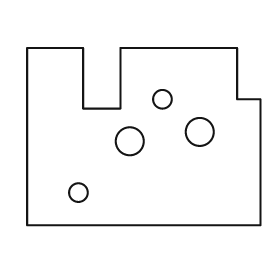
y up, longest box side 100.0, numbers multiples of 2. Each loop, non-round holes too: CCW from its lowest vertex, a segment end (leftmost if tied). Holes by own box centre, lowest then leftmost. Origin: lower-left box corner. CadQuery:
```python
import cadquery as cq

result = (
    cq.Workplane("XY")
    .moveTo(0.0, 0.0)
    .lineTo(100.0, 0.0)
    .lineTo(100.0, 54.0)
    .lineTo(90.0, 54.0)
    .lineTo(90.0, 76.0)
    .lineTo(40.0, 76.0)
    .lineTo(40.0, 50.0)
    .lineTo(24.0, 50.0)
    .lineTo(24.0, 76.0)
    .lineTo(0.0, 76.0)
    .close()
    .moveTo(22.0, 14.0)
    .circle(4.0)
    .moveTo(44.0, 36.0)
    .circle(6.0)
    .moveTo(74.0, 40.0)
    .circle(6.0)
    .moveTo(58.0, 54.0)
    .circle(4.0)
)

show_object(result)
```